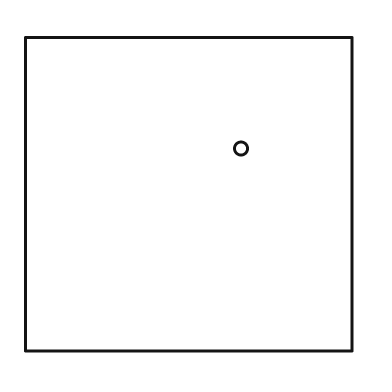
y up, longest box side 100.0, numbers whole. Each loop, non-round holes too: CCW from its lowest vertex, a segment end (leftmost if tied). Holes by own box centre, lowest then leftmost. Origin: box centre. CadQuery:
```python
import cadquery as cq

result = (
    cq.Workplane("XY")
    .moveTo(-50.0, -48.0)
    .lineTo(50.0, -48.0)
    .lineTo(50.0, 48.0)
    .lineTo(-50.0, 48.0)
    .close()
    .moveTo(16.0, 14.0)
    .circle(2.0)
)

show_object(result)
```